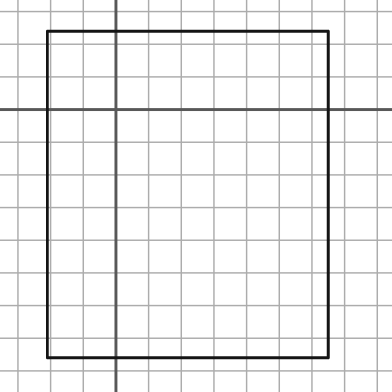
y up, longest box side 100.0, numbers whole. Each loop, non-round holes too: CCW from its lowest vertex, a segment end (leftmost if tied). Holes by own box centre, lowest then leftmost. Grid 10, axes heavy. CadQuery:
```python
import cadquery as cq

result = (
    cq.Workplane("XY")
    .moveTo(-21.0, -76.0)
    .lineTo(65.0, -76.0)
    .lineTo(65.0, 24.0)
    .lineTo(-21.0, 24.0)
    .close()
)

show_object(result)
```